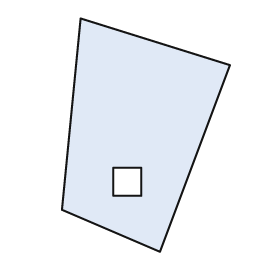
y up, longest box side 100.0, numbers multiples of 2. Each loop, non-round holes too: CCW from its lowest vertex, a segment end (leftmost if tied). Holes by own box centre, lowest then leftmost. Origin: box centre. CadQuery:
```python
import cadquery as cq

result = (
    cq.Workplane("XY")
    .moveTo(6.0, -50.0)
    .lineTo(36.0, 30.0)
    .lineTo(-28.0, 50.0)
    .lineTo(-36.0, -32.0)
    .close()
    .moveTo(-14.0, -26.0)
    .lineTo(-2.0, -26.0)
    .lineTo(-2.0, -14.0)
    .lineTo(-14.0, -14.0)
    .close()
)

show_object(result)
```